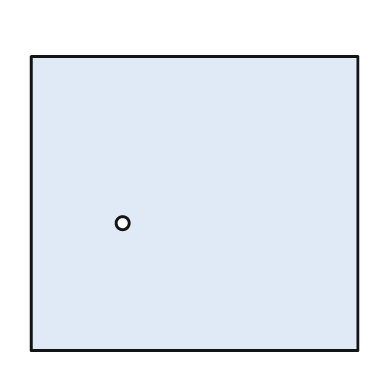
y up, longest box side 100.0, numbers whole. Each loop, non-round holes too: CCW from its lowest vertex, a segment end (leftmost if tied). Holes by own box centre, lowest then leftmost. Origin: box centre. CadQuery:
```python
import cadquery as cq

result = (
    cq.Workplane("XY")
    .moveTo(-50.0, -45.0)
    .lineTo(50.0, -45.0)
    .lineTo(50.0, 45.0)
    .lineTo(-50.0, 45.0)
    .close()
    .moveTo(-22.0, -6.0)
    .circle(2.0)
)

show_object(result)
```